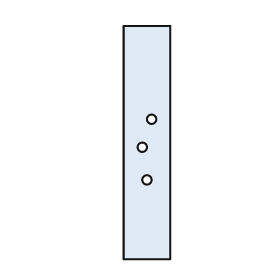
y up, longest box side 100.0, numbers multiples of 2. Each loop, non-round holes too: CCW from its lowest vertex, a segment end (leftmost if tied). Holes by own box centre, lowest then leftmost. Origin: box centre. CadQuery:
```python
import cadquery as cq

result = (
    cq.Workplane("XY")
    .moveTo(-10.0, -50.0)
    .lineTo(10.0, -50.0)
    .lineTo(10.0, 50.0)
    .lineTo(-10.0, 50.0)
    .close()
    .moveTo(0.0, -16.0)
    .circle(2.0)
    .moveTo(-2.0, -2.0)
    .circle(2.0)
    .moveTo(2.0, 10.0)
    .circle(2.0)
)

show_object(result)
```